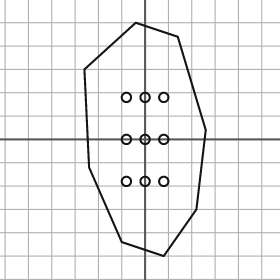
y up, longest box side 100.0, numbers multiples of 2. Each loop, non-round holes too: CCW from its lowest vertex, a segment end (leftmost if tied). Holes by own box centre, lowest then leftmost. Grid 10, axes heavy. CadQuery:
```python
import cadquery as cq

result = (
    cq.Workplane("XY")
    .moveTo(8.0, -50.0)
    .lineTo(22.0, -30.0)
    .lineTo(26.0, 4.0)
    .lineTo(14.0, 44.0)
    .lineTo(-4.0, 50.0)
    .lineTo(-26.0, 30.0)
    .lineTo(-24.0, -12.0)
    .lineTo(-10.0, -44.0)
    .close()
    .moveTo(-8.0, -18.0)
    .circle(2.0)
    .moveTo(0.0, -18.0)
    .circle(2.0)
    .moveTo(8.0, -18.0)
    .circle(2.0)
    .moveTo(-8.0, 0.0)
    .circle(2.0)
    .moveTo(0.0, 0.0)
    .circle(2.0)
    .moveTo(8.0, 0.0)
    .circle(2.0)
    .moveTo(-8.0, 18.0)
    .circle(2.0)
    .moveTo(0.0, 18.0)
    .circle(2.0)
    .moveTo(8.0, 18.0)
    .circle(2.0)
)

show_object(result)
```